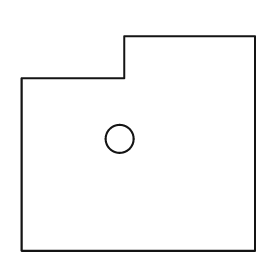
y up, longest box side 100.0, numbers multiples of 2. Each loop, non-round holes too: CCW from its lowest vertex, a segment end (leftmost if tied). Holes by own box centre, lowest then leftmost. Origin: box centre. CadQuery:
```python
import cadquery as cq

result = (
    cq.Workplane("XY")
    .moveTo(-50.0, -46.0)
    .lineTo(50.0, -46.0)
    .lineTo(50.0, 46.0)
    .lineTo(-6.0, 46.0)
    .lineTo(-6.0, 28.0)
    .lineTo(-50.0, 28.0)
    .close()
    .moveTo(-8.0, 2.0)
    .circle(6.0)
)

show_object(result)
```